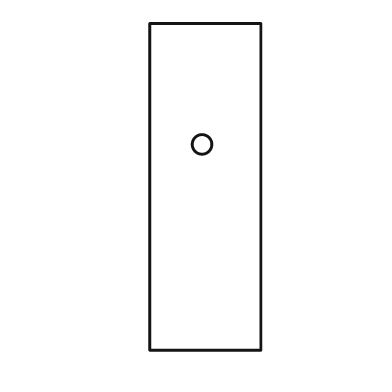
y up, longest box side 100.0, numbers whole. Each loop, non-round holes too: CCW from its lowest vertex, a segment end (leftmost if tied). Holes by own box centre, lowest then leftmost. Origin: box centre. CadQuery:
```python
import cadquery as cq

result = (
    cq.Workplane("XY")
    .moveTo(-17.0, -50.0)
    .lineTo(17.0, -50.0)
    .lineTo(17.0, 50.0)
    .lineTo(-17.0, 50.0)
    .close()
    .moveTo(-1.0, 13.0)
    .circle(3.0)
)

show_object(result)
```